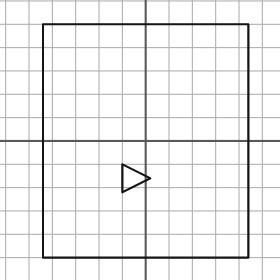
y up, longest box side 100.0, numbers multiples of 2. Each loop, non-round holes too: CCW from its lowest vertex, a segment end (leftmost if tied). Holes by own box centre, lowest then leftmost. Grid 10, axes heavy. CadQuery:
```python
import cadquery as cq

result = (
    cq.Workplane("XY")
    .moveTo(-44.0, -50.0)
    .lineTo(44.0, -50.0)
    .lineTo(44.0, 50.0)
    .lineTo(-44.0, 50.0)
    .close()
    .moveTo(-10.0, -22.0)
    .lineTo(2.0, -16.0)
    .lineTo(-10.0, -10.0)
    .close()
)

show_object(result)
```